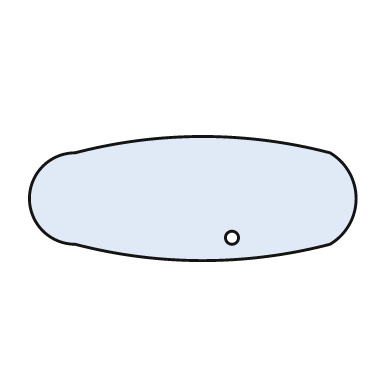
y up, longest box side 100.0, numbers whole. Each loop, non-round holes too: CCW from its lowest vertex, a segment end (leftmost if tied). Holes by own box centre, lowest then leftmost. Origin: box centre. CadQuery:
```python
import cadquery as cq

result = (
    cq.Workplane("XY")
    .moveTo(-36.0, -14.0)
    .threePointArc((3.0, -19.0), (42.0, -14.0))
    .threePointArc((50.0, 0.0), (42.0, 14.0))
    .threePointArc((3.0, 19.0), (-36.0, 14.0))
    .threePointArc((-50.0, 0.0), (-36.0, -14.0))
    .close()
    .moveTo(12.0, -12.0)
    .circle(2.0)
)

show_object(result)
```